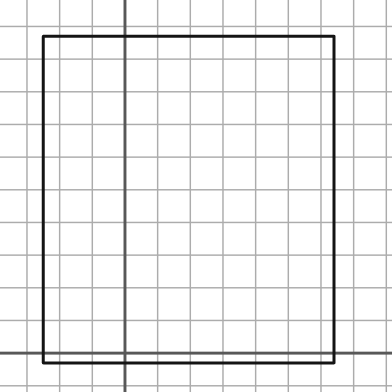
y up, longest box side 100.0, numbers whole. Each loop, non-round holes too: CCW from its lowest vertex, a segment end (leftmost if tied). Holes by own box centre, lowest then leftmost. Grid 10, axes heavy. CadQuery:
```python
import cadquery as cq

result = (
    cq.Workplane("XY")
    .moveTo(-25.0, -3.0)
    .lineTo(64.0, -3.0)
    .lineTo(64.0, 97.0)
    .lineTo(-25.0, 97.0)
    .close()
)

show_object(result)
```